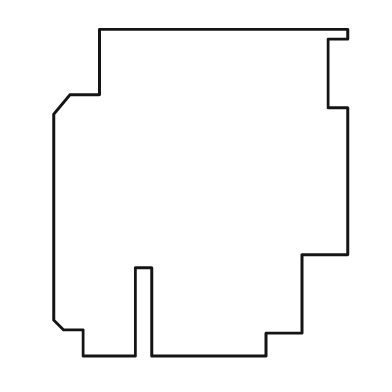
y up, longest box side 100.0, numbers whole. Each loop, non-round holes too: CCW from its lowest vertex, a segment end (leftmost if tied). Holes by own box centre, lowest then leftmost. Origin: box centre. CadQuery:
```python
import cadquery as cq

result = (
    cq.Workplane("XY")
    .moveTo(-36.0, -50.0)
    .lineTo(-20.0, -50.0)
    .lineTo(-20.0, -23.0)
    .lineTo(-15.0, -23.0)
    .lineTo(-15.0, -50.0)
    .lineTo(20.0, -50.0)
    .lineTo(20.0, -43.0)
    .lineTo(31.0, -43.0)
    .lineTo(31.0, -19.0)
    .lineTo(45.0, -19.0)
    .lineTo(45.0, 26.0)
    .lineTo(39.0, 26.0)
    .lineTo(39.0, 47.0)
    .lineTo(45.0, 47.0)
    .lineTo(45.0, 50.0)
    .lineTo(-31.0, 50.0)
    .lineTo(-31.0, 30.0)
    .lineTo(-40.0, 30.0)
    .lineTo(-45.0, 24.0)
    .lineTo(-45.0, -39.0)
    .lineTo(-42.0, -42.0)
    .lineTo(-36.0, -42.0)
    .close()
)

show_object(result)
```